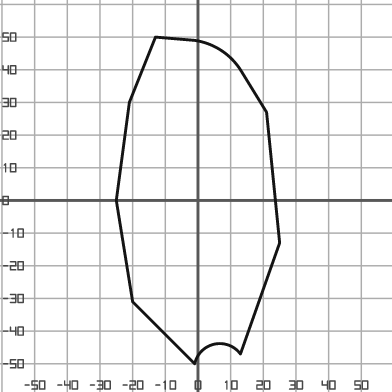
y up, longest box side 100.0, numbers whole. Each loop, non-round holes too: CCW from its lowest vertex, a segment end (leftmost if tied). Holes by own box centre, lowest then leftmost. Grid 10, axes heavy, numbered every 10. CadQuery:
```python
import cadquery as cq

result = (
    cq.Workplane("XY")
    .moveTo(-1.0, -50.0)
    .threePointArc((5.0, -44.0), (13.0, -47.0))
    .lineTo(25.0, -13.0)
    .lineTo(21.0, 27.0)
    .lineTo(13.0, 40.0)
    .threePointArc((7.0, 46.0), (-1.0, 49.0))
    .lineTo(-13.0, 50.0)
    .lineTo(-21.0, 30.0)
    .lineTo(-25.0, 0.0)
    .lineTo(-20.0, -31.0)
    .close()
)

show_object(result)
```